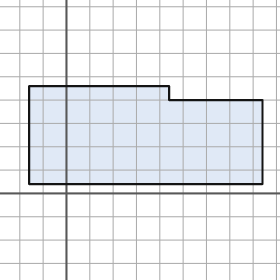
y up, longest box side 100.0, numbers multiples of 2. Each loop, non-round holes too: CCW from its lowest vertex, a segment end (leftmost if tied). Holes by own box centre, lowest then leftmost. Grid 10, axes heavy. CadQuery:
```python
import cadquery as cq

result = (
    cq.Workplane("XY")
    .moveTo(-16.0, 4.0)
    .lineTo(84.0, 4.0)
    .lineTo(84.0, 40.0)
    .lineTo(44.0, 40.0)
    .lineTo(44.0, 46.0)
    .lineTo(-16.0, 46.0)
    .close()
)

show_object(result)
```